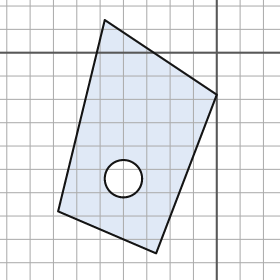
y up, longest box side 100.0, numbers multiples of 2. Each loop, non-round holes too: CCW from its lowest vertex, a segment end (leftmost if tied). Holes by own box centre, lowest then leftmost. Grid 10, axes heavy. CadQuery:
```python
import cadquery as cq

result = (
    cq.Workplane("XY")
    .moveTo(-26.0, -86.0)
    .lineTo(0.0, -18.0)
    .lineTo(-48.0, 14.0)
    .lineTo(-68.0, -68.0)
    .close()
    .moveTo(-40.0, -54.0)
    .circle(8.0)
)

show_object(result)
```